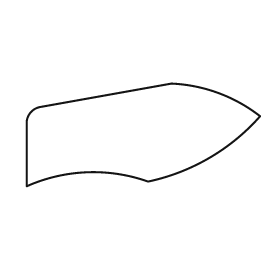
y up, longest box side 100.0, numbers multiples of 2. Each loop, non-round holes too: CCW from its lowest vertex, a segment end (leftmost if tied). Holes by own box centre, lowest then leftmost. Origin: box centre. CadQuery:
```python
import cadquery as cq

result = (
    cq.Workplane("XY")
    .moveTo(-50.0, -22.0)
    .threePointArc((-24.0, -16.0), (2.0, -20.0))
    .threePointArc((28.0, -10.0), (50.0, 8.0))
    .threePointArc((32.0, 18.0), (12.0, 22.0))
    .lineTo(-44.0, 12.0)
    .threePointArc((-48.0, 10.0), (-50.0, 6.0))
    .close()
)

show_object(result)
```